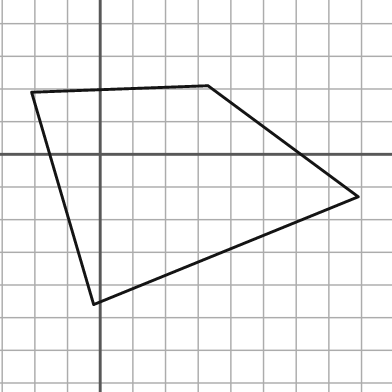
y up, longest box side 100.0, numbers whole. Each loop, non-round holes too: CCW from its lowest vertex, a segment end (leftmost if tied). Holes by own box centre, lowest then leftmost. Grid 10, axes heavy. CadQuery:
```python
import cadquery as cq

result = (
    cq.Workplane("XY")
    .moveTo(-2.0, -46.0)
    .lineTo(79.0, -13.0)
    .lineTo(33.0, 21.0)
    .lineTo(-21.0, 19.0)
    .close()
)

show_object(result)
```